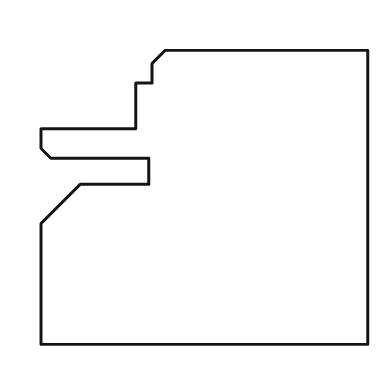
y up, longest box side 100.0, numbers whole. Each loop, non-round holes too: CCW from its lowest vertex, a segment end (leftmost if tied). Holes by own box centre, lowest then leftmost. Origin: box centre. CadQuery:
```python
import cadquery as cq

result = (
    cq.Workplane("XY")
    .moveTo(-50.0, -45.0)
    .lineTo(50.0, -45.0)
    .lineTo(50.0, 45.0)
    .lineTo(-12.0, 45.0)
    .lineTo(-16.0, 41.0)
    .lineTo(-16.0, 35.0)
    .lineTo(-21.0, 35.0)
    .lineTo(-21.0, 21.0)
    .lineTo(-50.0, 21.0)
    .lineTo(-50.0, 15.0)
    .lineTo(-47.0, 12.0)
    .lineTo(-17.0, 12.0)
    .lineTo(-17.0, 4.0)
    .lineTo(-38.0, 4.0)
    .lineTo(-50.0, -8.0)
    .close()
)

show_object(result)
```